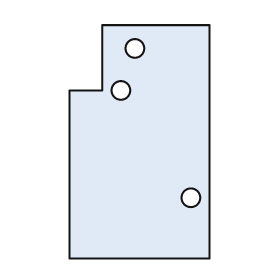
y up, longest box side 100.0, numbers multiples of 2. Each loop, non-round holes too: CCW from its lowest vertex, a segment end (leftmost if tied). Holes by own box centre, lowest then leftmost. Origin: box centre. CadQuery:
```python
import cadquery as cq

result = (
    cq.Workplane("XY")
    .moveTo(-30.0, -50.0)
    .lineTo(30.0, -50.0)
    .lineTo(30.0, 50.0)
    .lineTo(-16.0, 50.0)
    .lineTo(-16.0, 22.0)
    .lineTo(-30.0, 22.0)
    .close()
    .moveTo(22.0, -24.0)
    .circle(4.0)
    .moveTo(-8.0, 22.0)
    .circle(4.0)
    .moveTo(-2.0, 40.0)
    .circle(4.0)
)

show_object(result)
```